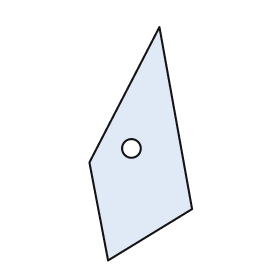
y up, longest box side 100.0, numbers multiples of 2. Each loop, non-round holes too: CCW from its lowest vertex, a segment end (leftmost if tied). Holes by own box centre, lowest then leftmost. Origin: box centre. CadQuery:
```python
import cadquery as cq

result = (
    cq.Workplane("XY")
    .moveTo(-14.0, -50.0)
    .lineTo(22.0, -28.0)
    .lineTo(8.0, 50.0)
    .lineTo(-22.0, -8.0)
    .close()
    .moveTo(-4.0, -2.0)
    .circle(4.0)
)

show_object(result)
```